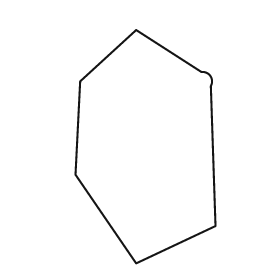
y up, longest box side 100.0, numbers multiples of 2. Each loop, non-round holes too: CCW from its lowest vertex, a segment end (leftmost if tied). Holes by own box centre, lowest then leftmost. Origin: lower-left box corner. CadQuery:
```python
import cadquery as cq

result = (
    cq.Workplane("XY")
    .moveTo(26.0, 0.0)
    .lineTo(60.0, 16.0)
    .lineTo(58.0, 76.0)
    .threePointArc((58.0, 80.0), (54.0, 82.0))
    .lineTo(26.0, 100.0)
    .lineTo(2.0, 78.0)
    .lineTo(0.0, 38.0)
    .close()
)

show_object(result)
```